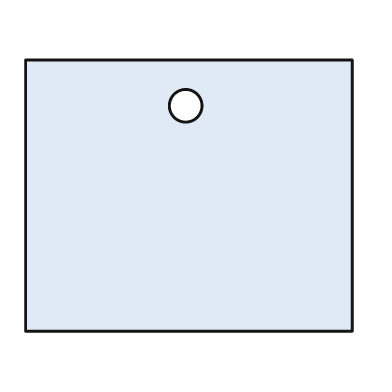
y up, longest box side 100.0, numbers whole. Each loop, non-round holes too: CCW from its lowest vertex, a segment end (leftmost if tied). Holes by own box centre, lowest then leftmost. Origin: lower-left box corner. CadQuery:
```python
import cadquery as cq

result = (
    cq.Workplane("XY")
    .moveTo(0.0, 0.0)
    .lineTo(100.0, 0.0)
    .lineTo(100.0, 83.0)
    .lineTo(0.0, 83.0)
    .close()
    .moveTo(49.0, 69.0)
    .circle(5.0)
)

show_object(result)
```